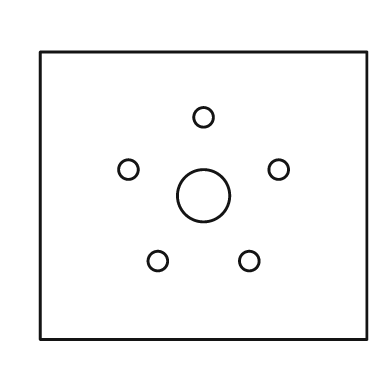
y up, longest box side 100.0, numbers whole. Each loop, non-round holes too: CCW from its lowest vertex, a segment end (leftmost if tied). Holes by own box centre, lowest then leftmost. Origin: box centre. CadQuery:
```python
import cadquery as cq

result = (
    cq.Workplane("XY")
    .moveTo(-50.0, -44.0)
    .lineTo(50.0, -44.0)
    .lineTo(50.0, 44.0)
    .lineTo(-50.0, 44.0)
    .close()
    .moveTo(-14.0, -20.0)
    .circle(3.0)
    .moveTo(14.0, -20.0)
    .circle(3.0)
    .moveTo(0.0, 0.0)
    .circle(8.0)
    .moveTo(-23.0, 8.0)
    .circle(3.0)
    .moveTo(23.0, 8.0)
    .circle(3.0)
    .moveTo(0.0, 24.0)
    .circle(3.0)
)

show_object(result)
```